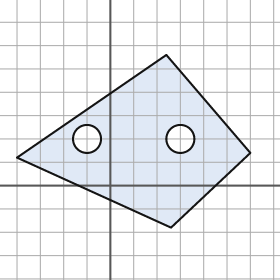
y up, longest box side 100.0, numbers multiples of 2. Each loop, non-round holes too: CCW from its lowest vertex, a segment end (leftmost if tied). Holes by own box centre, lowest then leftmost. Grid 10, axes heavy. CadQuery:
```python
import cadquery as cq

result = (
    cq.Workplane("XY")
    .moveTo(26.0, -18.0)
    .lineTo(60.0, 14.0)
    .lineTo(24.0, 56.0)
    .lineTo(-40.0, 12.0)
    .close()
    .moveTo(-10.0, 20.0)
    .circle(6.0)
    .moveTo(30.0, 20.0)
    .circle(6.0)
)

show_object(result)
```